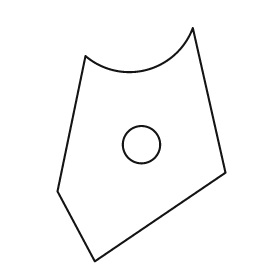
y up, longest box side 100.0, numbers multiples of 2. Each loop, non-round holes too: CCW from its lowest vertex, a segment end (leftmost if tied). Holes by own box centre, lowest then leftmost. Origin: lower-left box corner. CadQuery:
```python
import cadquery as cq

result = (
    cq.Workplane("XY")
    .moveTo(16.0, 0.0)
    .lineTo(72.0, 38.0)
    .lineTo(58.0, 100.0)
    .threePointArc((38.0, 82.0), (12.0, 88.0))
    .lineTo(0.0, 30.0)
    .close()
    .moveTo(36.0, 50.0)
    .circle(8.0)
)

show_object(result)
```